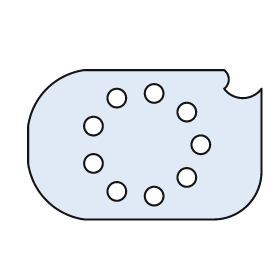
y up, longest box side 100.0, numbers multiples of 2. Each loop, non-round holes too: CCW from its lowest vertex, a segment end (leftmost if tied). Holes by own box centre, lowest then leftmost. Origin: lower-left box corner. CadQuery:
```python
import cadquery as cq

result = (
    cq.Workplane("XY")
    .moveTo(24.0, 0.0)
    .lineTo(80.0, 0.0)
    .threePointArc((94.0, 6.0), (100.0, 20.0))
    .lineTo(100.0, 56.0)
    .threePointArc((92.0, 52.0), (84.0, 56.0))
    .threePointArc((86.0, 60.0), (84.0, 64.0))
    .lineTo(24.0, 64.0)
    .threePointArc((8.0, 56.0), (0.0, 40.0))
    .lineTo(0.0, 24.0)
    .threePointArc((8.0, 8.0), (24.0, 0.0))
    .close()
    .moveTo(54.0, 10.0)
    .circle(4.0)
    .moveTo(38.0, 12.0)
    .circle(4.0)
    .moveTo(68.0, 18.0)
    .circle(4.0)
    .moveTo(28.0, 24.0)
    .circle(4.0)
    .moveTo(74.0, 32.0)
    .circle(4.0)
    .moveTo(28.0, 40.0)
    .circle(4.0)
    .moveTo(68.0, 46.0)
    .circle(4.0)
    .moveTo(38.0, 52.0)
    .circle(4.0)
    .moveTo(54.0, 54.0)
    .circle(4.0)
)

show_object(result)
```